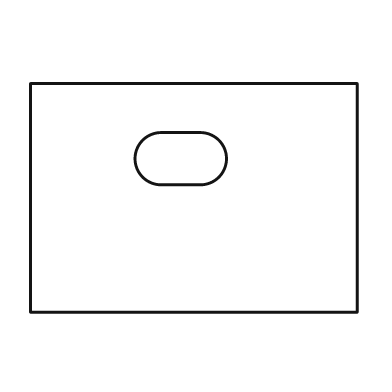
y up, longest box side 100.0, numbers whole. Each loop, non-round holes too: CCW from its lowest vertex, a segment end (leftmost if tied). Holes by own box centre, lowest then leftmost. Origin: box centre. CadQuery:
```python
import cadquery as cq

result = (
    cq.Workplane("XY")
    .moveTo(-50.0, -35.0)
    .lineTo(50.0, -35.0)
    .lineTo(50.0, 35.0)
    .lineTo(-50.0, 35.0)
    .close()
    .moveTo(-10.0, 4.0)
    .lineTo(2.0, 4.0)
    .threePointArc((10.0, 12.0), (2.0, 20.0))
    .lineTo(-10.0, 20.0)
    .threePointArc((-18.0, 12.0), (-10.0, 4.0))
    .close()
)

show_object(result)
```